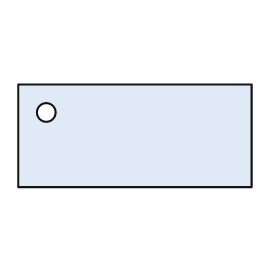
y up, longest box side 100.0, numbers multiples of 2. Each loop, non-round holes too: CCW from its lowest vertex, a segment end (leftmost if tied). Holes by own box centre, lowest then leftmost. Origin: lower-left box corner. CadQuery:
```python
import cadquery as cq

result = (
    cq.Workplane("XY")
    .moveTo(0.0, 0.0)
    .lineTo(100.0, 0.0)
    .lineTo(100.0, 44.0)
    .lineTo(0.0, 44.0)
    .close()
    .moveTo(12.0, 32.0)
    .circle(4.0)
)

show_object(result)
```